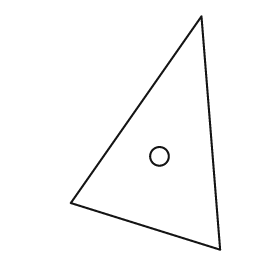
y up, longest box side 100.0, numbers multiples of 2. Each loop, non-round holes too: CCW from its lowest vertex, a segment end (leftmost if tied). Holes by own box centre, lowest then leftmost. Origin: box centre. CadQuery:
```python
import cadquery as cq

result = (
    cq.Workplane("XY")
    .moveTo(32.0, -50.0)
    .lineTo(24.0, 50.0)
    .lineTo(-32.0, -30.0)
    .close()
    .moveTo(6.0, -10.0)
    .circle(4.0)
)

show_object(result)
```